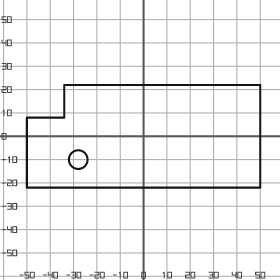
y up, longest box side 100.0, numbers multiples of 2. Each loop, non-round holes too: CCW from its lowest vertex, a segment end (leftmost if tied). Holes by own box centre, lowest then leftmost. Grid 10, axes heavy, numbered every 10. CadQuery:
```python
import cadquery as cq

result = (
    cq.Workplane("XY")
    .moveTo(-50.0, -22.0)
    .lineTo(50.0, -22.0)
    .lineTo(50.0, 22.0)
    .lineTo(-34.0, 22.0)
    .lineTo(-34.0, 8.0)
    .lineTo(-50.0, 8.0)
    .close()
    .moveTo(-28.0, -10.0)
    .circle(4.0)
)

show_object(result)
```